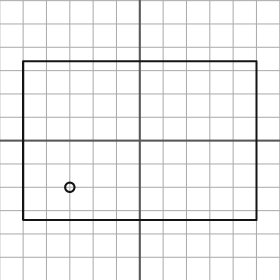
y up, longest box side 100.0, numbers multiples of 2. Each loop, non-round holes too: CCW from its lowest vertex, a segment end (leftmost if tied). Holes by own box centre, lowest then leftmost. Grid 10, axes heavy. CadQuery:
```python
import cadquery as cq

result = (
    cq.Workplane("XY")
    .moveTo(-50.0, -34.0)
    .lineTo(50.0, -34.0)
    .lineTo(50.0, 34.0)
    .lineTo(-50.0, 34.0)
    .close()
    .moveTo(-30.0, -20.0)
    .circle(2.0)
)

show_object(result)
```